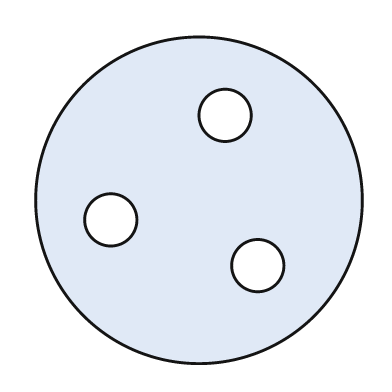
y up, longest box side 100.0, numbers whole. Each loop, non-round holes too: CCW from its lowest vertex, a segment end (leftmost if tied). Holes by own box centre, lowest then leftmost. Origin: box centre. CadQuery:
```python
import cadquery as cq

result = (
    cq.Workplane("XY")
    .moveTo(0.0, 0.0)
    .circle(50.0)
    .moveTo(18.0, -20.0)
    .circle(8.0)
    .moveTo(-27.0, -6.0)
    .circle(8.0)
    .moveTo(8.0, 26.0)
    .circle(8.0)
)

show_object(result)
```